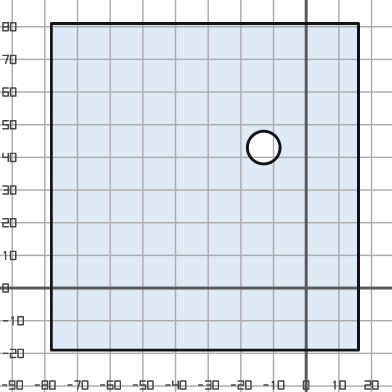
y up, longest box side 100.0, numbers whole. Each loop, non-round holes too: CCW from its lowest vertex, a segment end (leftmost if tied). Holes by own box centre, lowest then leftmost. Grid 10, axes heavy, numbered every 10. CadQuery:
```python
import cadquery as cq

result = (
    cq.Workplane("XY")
    .moveTo(-78.0, -19.0)
    .lineTo(16.0, -19.0)
    .lineTo(16.0, 81.0)
    .lineTo(-78.0, 81.0)
    .close()
    .moveTo(-13.0, 43.0)
    .circle(5.0)
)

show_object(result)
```